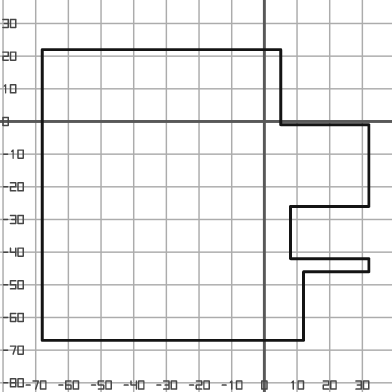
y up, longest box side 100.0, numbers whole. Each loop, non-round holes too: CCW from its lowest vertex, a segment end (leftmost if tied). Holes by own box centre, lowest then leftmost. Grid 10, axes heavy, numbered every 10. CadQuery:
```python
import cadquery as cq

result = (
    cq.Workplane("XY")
    .moveTo(-68.0, -67.0)
    .lineTo(12.0, -67.0)
    .lineTo(12.0, -46.0)
    .lineTo(32.0, -46.0)
    .lineTo(32.0, -42.0)
    .lineTo(8.0, -42.0)
    .lineTo(8.0, -26.0)
    .lineTo(32.0, -26.0)
    .lineTo(32.0, -1.0)
    .lineTo(5.0, -1.0)
    .lineTo(5.0, 22.0)
    .lineTo(-68.0, 22.0)
    .close()
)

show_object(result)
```